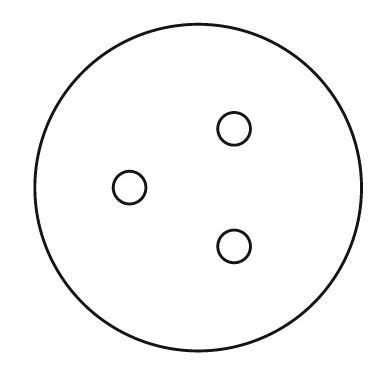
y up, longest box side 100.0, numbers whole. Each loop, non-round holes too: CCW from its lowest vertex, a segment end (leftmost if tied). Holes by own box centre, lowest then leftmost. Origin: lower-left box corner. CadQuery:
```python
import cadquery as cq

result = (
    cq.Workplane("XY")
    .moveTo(50.0, 50.0)
    .circle(50.0)
    .moveTo(61.0, 32.0)
    .circle(5.0)
    .moveTo(29.0, 50.0)
    .circle(5.0)
    .moveTo(61.0, 68.0)
    .circle(5.0)
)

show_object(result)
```